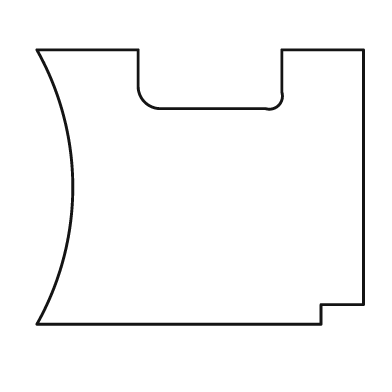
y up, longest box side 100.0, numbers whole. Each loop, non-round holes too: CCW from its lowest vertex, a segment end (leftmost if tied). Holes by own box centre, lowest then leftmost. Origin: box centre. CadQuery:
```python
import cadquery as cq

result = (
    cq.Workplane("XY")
    .moveTo(-50.0, -42.0)
    .lineTo(37.0, -42.0)
    .lineTo(37.0, -36.0)
    .lineTo(50.0, -36.0)
    .lineTo(50.0, 42.0)
    .lineTo(25.0, 42.0)
    .lineTo(25.0, 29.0)
    .threePointArc((24.0, 25.0), (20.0, 24.0))
    .lineTo(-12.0, 24.0)
    .threePointArc((-17.0, 26.0), (-19.0, 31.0))
    .lineTo(-19.0, 42.0)
    .lineTo(-50.0, 42.0)
    .threePointArc((-39.0, 0.0), (-50.0, -42.0))
    .close()
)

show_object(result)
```